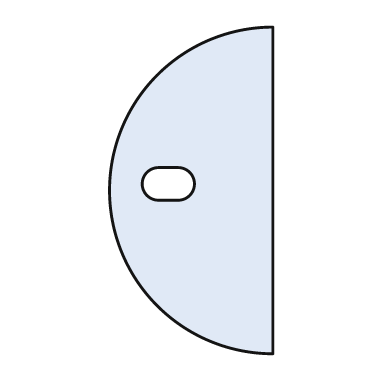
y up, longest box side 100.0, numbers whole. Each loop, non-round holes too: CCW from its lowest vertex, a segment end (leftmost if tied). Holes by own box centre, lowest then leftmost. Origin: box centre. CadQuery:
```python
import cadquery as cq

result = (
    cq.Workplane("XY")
    .moveTo(25.0, -50.0)
    .lineTo(25.0, 50.0)
    .threePointArc((-25.0, 0.0), (25.0, -50.0))
    .close()
    .moveTo(-10.0, -3.0)
    .lineTo(-4.0, -3.0)
    .threePointArc((1.0, 2.0), (-4.0, 7.0))
    .lineTo(-10.0, 7.0)
    .threePointArc((-15.0, 2.0), (-10.0, -3.0))
    .close()
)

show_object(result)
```